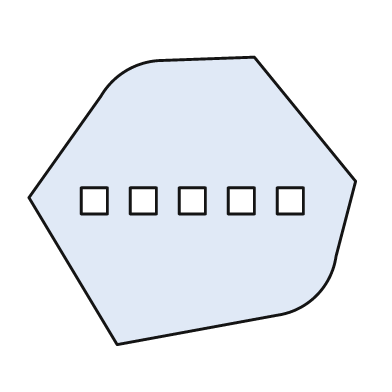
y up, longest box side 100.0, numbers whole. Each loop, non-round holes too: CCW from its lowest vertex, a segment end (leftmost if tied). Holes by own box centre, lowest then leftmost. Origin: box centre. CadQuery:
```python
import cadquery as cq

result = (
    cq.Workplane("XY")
    .moveTo(-23.0, -44.0)
    .lineTo(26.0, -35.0)
    .threePointArc((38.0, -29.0), (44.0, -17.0))
    .lineTo(50.0, 6.0)
    .lineTo(19.0, 44.0)
    .lineTo(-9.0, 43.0)
    .threePointArc((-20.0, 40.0), (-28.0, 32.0))
    .lineTo(-50.0, 1.0)
    .close()
    .moveTo(-34.0, -4.0)
    .lineTo(-26.0, -4.0)
    .lineTo(-26.0, 4.0)
    .lineTo(-34.0, 4.0)
    .close()
    .moveTo(-19.0, -4.0)
    .lineTo(-11.0, -4.0)
    .lineTo(-11.0, 4.0)
    .lineTo(-19.0, 4.0)
    .close()
    .moveTo(-4.0, -4.0)
    .lineTo(4.0, -4.0)
    .lineTo(4.0, 4.0)
    .lineTo(-4.0, 4.0)
    .close()
    .moveTo(11.0, -4.0)
    .lineTo(19.0, -4.0)
    .lineTo(19.0, 4.0)
    .lineTo(11.0, 4.0)
    .close()
    .moveTo(26.0, -4.0)
    .lineTo(34.0, -4.0)
    .lineTo(34.0, 4.0)
    .lineTo(26.0, 4.0)
    .close()
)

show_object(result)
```